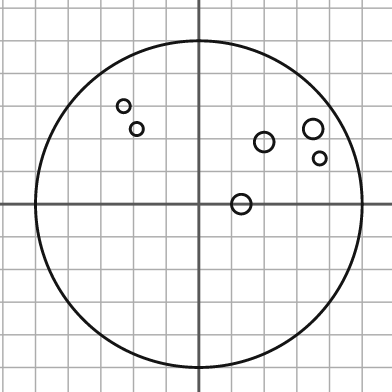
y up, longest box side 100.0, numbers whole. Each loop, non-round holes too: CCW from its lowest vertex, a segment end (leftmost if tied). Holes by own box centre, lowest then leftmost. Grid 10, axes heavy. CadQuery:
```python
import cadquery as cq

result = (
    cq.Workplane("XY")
    .moveTo(0.0, 0.0)
    .circle(50.0)
    .moveTo(13.0, 0.0)
    .circle(3.0)
    .moveTo(37.0, 14.0)
    .circle(2.0)
    .moveTo(20.0, 19.0)
    .circle(3.0)
    .moveTo(-19.0, 23.0)
    .circle(2.0)
    .moveTo(35.0, 23.0)
    .circle(3.0)
    .moveTo(-23.0, 30.0)
    .circle(2.0)
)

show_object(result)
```